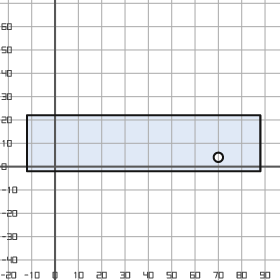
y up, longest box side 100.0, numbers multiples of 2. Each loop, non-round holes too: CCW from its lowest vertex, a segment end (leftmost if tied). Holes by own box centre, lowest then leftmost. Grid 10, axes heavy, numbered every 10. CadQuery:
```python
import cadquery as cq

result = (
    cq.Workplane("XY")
    .moveTo(-12.0, -2.0)
    .lineTo(88.0, -2.0)
    .lineTo(88.0, 22.0)
    .lineTo(-12.0, 22.0)
    .close()
    .moveTo(70.0, 4.0)
    .circle(2.0)
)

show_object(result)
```